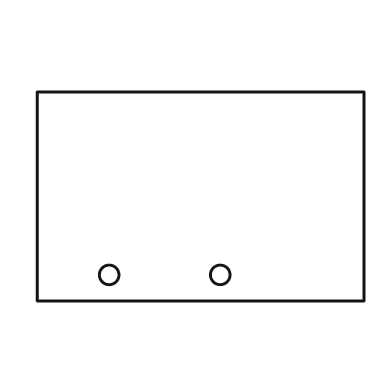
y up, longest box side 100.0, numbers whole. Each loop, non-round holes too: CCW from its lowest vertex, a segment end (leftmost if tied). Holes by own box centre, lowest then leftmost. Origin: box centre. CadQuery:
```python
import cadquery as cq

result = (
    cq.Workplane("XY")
    .moveTo(-50.0, -32.0)
    .lineTo(50.0, -32.0)
    .lineTo(50.0, 32.0)
    .lineTo(-50.0, 32.0)
    .close()
    .moveTo(-28.0, -24.0)
    .circle(3.0)
    .moveTo(6.0, -24.0)
    .circle(3.0)
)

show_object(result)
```